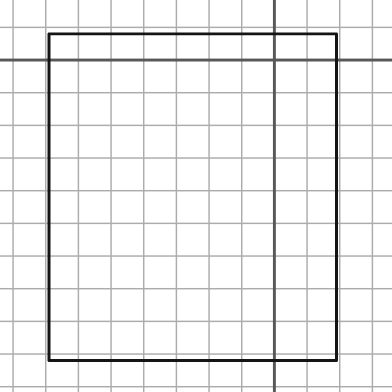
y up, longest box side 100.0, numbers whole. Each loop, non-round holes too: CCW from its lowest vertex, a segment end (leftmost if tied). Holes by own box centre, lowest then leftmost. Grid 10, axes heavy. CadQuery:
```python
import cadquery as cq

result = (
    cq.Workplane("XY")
    .moveTo(-69.0, -92.0)
    .lineTo(19.0, -92.0)
    .lineTo(19.0, 8.0)
    .lineTo(-69.0, 8.0)
    .close()
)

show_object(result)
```